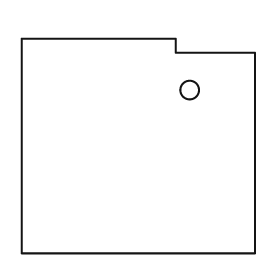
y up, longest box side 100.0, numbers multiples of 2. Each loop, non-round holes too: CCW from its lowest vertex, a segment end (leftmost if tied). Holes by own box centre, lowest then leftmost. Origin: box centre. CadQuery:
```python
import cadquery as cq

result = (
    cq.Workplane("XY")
    .moveTo(-50.0, -46.0)
    .lineTo(50.0, -46.0)
    .lineTo(50.0, 40.0)
    .lineTo(16.0, 40.0)
    .lineTo(16.0, 46.0)
    .lineTo(-50.0, 46.0)
    .close()
    .moveTo(22.0, 24.0)
    .circle(4.0)
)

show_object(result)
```